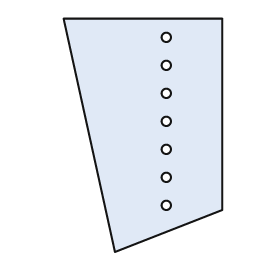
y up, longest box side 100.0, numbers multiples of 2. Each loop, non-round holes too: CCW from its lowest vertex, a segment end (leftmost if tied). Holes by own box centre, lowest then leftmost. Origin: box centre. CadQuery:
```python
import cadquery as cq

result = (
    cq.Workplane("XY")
    .moveTo(-12.0, -50.0)
    .lineTo(34.0, -32.0)
    .lineTo(34.0, 50.0)
    .lineTo(-34.0, 50.0)
    .close()
    .moveTo(10.0, -30.0)
    .circle(2.0)
    .moveTo(10.0, -18.0)
    .circle(2.0)
    .moveTo(10.0, -6.0)
    .circle(2.0)
    .moveTo(10.0, 6.0)
    .circle(2.0)
    .moveTo(10.0, 18.0)
    .circle(2.0)
    .moveTo(10.0, 30.0)
    .circle(2.0)
    .moveTo(10.0, 42.0)
    .circle(2.0)
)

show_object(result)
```